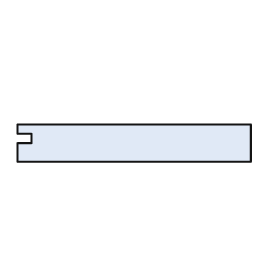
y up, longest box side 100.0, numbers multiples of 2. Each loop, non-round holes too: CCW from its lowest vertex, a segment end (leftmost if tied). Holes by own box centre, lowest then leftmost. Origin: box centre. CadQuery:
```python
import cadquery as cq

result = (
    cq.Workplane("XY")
    .moveTo(-50.0, -8.0)
    .lineTo(50.0, -8.0)
    .lineTo(50.0, 8.0)
    .lineTo(-50.0, 8.0)
    .lineTo(-50.0, 4.0)
    .lineTo(-44.0, 4.0)
    .lineTo(-44.0, 0.0)
    .lineTo(-50.0, 0.0)
    .close()
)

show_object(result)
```